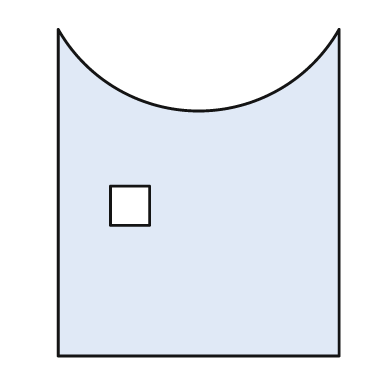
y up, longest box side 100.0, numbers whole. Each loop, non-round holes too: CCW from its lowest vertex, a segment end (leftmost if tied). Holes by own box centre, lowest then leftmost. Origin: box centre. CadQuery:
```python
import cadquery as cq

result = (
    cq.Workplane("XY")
    .moveTo(-43.0, -50.0)
    .lineTo(43.0, -50.0)
    .lineTo(43.0, 50.0)
    .threePointArc((0.0, 25.0), (-43.0, 50.0))
    .close()
    .moveTo(-27.0, -10.0)
    .lineTo(-15.0, -10.0)
    .lineTo(-15.0, 2.0)
    .lineTo(-27.0, 2.0)
    .close()
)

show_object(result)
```